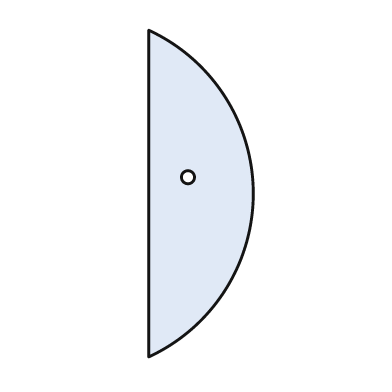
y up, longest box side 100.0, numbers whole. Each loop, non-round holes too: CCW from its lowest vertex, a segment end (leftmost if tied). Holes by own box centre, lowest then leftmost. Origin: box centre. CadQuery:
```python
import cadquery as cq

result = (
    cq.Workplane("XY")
    .moveTo(-16.0, -50.0)
    .threePointArc((16.0, 0.0), (-16.0, 50.0))
    .close()
    .moveTo(-4.0, 5.0)
    .circle(2.0)
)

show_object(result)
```